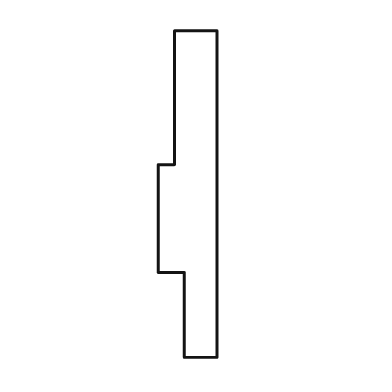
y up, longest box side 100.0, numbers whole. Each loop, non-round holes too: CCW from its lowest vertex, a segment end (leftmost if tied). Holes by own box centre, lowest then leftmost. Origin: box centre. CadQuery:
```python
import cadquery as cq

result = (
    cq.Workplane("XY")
    .moveTo(-1.0, -50.0)
    .lineTo(9.0, -50.0)
    .lineTo(9.0, 50.0)
    .lineTo(-4.0, 50.0)
    .lineTo(-4.0, 9.0)
    .lineTo(-9.0, 9.0)
    .lineTo(-9.0, -24.0)
    .lineTo(-1.0, -24.0)
    .close()
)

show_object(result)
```